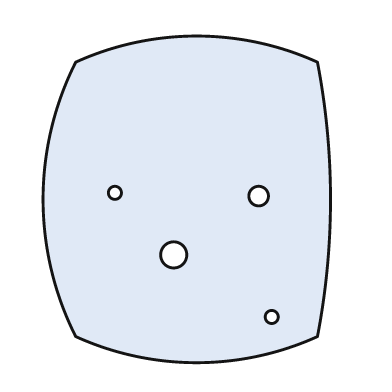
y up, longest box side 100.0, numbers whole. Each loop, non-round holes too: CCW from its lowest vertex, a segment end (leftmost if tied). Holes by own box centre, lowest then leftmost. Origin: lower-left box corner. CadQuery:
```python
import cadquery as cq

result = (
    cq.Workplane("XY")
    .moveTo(10.0, 8.0)
    .threePointArc((47.0, 0.0), (84.0, 8.0))
    .threePointArc((88.0, 50.0), (84.0, 92.0))
    .threePointArc((47.0, 100.0), (10.0, 92.0))
    .threePointArc((0.0, 50.0), (10.0, 8.0))
    .close()
    .moveTo(70.0, 14.0)
    .circle(2.0)
    .moveTo(40.0, 33.0)
    .circle(4.0)
    .moveTo(66.0, 51.0)
    .circle(3.0)
    .moveTo(22.0, 52.0)
    .circle(2.0)
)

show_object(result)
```